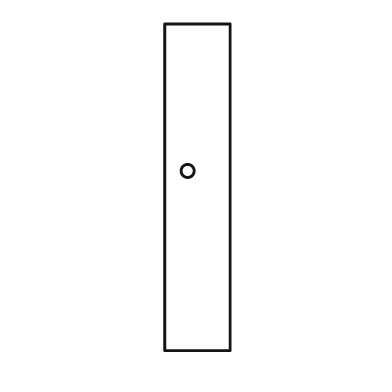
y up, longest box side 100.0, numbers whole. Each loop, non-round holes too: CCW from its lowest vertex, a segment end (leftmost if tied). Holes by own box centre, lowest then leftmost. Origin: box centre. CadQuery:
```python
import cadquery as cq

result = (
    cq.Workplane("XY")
    .moveTo(-10.0, -50.0)
    .lineTo(10.0, -50.0)
    .lineTo(10.0, 50.0)
    .lineTo(-10.0, 50.0)
    .close()
    .moveTo(-3.0, 5.0)
    .circle(2.0)
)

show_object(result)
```